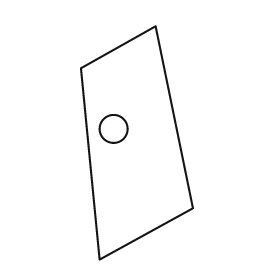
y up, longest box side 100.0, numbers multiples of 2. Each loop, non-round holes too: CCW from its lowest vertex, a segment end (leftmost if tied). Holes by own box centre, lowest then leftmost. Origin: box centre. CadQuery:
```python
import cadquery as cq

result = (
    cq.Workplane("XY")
    .moveTo(-16.0, -50.0)
    .lineTo(24.0, -28.0)
    .lineTo(8.0, 50.0)
    .lineTo(-24.0, 32.0)
    .close()
    .moveTo(-10.0, 6.0)
    .circle(6.0)
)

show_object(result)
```